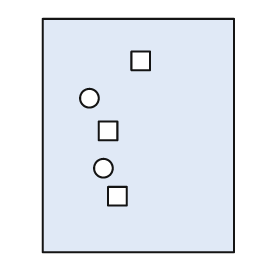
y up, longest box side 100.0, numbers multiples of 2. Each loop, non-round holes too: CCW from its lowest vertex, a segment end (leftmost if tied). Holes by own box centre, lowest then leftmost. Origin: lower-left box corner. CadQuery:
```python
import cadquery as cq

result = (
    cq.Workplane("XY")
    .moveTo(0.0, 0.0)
    .lineTo(82.0, 0.0)
    .lineTo(82.0, 100.0)
    .lineTo(0.0, 100.0)
    .close()
    .moveTo(28.0, 20.0)
    .lineTo(36.0, 20.0)
    .lineTo(36.0, 28.0)
    .lineTo(28.0, 28.0)
    .close()
    .moveTo(26.0, 36.0)
    .circle(4.0)
    .moveTo(24.0, 48.0)
    .lineTo(32.0, 48.0)
    .lineTo(32.0, 56.0)
    .lineTo(24.0, 56.0)
    .close()
    .moveTo(20.0, 66.0)
    .circle(4.0)
    .moveTo(38.0, 78.0)
    .lineTo(46.0, 78.0)
    .lineTo(46.0, 86.0)
    .lineTo(38.0, 86.0)
    .close()
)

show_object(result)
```